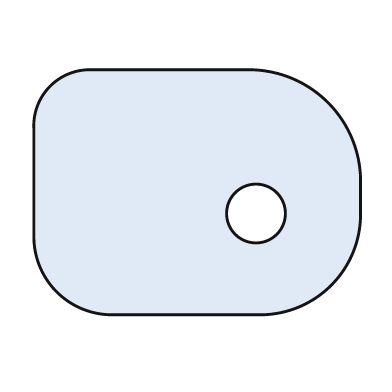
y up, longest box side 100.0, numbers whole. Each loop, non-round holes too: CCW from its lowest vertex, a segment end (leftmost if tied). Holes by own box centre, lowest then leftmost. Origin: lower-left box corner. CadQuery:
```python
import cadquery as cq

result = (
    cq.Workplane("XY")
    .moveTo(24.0, 0.0)
    .lineTo(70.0, 0.0)
    .threePointArc((91.0, 9.0), (100.0, 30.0))
    .lineTo(100.0, 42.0)
    .threePointArc((90.0, 65.0), (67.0, 75.0))
    .lineTo(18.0, 75.0)
    .threePointArc((5.0, 70.0), (0.0, 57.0))
    .lineTo(0.0, 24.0)
    .threePointArc((7.0, 7.0), (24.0, 0.0))
    .close()
    .moveTo(68.0, 31.0)
    .circle(9.0)
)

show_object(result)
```